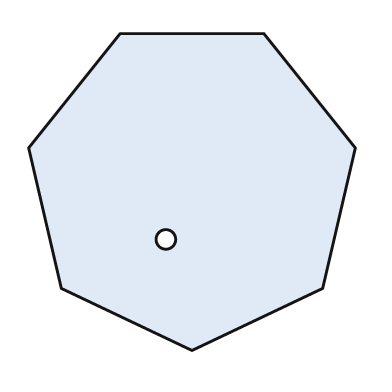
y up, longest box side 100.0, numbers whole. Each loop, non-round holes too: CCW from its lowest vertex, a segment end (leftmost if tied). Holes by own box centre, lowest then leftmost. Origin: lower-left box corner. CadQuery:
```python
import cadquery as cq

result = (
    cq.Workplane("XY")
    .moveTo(50.0, 0.0)
    .lineTo(90.0, 19.0)
    .lineTo(100.0, 62.0)
    .lineTo(72.0, 97.0)
    .lineTo(28.0, 97.0)
    .lineTo(0.0, 62.0)
    .lineTo(10.0, 19.0)
    .close()
    .moveTo(42.0, 34.0)
    .circle(3.0)
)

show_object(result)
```